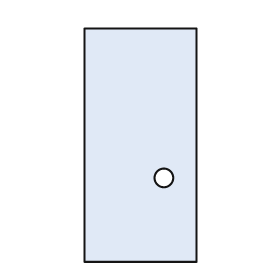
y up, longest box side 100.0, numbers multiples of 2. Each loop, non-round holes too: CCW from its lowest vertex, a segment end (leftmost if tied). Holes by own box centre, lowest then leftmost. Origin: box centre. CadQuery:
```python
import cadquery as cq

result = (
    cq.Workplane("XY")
    .moveTo(-24.0, -50.0)
    .lineTo(24.0, -50.0)
    .lineTo(24.0, 50.0)
    .lineTo(-24.0, 50.0)
    .close()
    .moveTo(10.0, -14.0)
    .circle(4.0)
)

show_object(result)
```